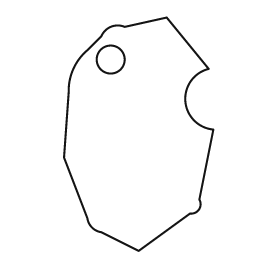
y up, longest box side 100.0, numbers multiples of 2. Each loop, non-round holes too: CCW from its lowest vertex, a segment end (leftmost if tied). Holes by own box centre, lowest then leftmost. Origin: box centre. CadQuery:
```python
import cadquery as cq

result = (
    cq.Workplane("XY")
    .moveTo(0.0, -50.0)
    .lineTo(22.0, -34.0)
    .threePointArc((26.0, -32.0), (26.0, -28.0))
    .lineTo(32.0, 2.0)
    .threePointArc((20.0, 14.0), (30.0, 28.0))
    .lineTo(12.0, 50.0)
    .lineTo(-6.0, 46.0)
    .threePointArc((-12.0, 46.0), (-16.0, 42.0))
    .lineTo(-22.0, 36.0)
    .threePointArc((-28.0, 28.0), (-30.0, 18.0))
    .lineTo(-32.0, -10.0)
    .lineTo(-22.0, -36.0)
    .threePointArc((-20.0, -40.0), (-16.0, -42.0))
    .close()
    .moveTo(-12.0, 32.0)
    .circle(6.0)
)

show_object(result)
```